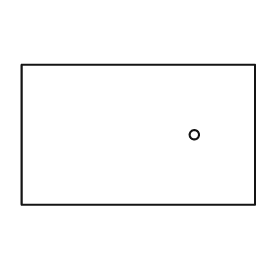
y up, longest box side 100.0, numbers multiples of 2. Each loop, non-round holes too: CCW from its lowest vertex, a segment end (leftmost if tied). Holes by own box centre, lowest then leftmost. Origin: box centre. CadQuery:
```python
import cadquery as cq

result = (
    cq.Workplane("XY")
    .moveTo(-50.0, -30.0)
    .lineTo(50.0, -30.0)
    .lineTo(50.0, 30.0)
    .lineTo(-50.0, 30.0)
    .close()
    .moveTo(24.0, 0.0)
    .circle(2.0)
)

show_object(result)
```